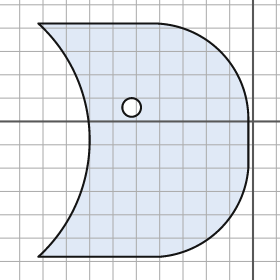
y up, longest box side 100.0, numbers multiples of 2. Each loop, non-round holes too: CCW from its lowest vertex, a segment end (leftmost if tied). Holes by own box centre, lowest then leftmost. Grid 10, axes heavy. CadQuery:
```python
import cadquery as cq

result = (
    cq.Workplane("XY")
    .moveTo(-92.0, -58.0)
    .lineTo(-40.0, -58.0)
    .threePointArc((-14.0, -46.0), (-2.0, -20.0))
    .lineTo(-2.0, 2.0)
    .threePointArc((-14.0, 30.0), (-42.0, 42.0))
    .lineTo(-92.0, 42.0)
    .threePointArc((-70.0, -8.0), (-92.0, -58.0))
    .close()
    .moveTo(-52.0, 6.0)
    .circle(4.0)
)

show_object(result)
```